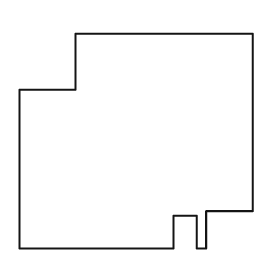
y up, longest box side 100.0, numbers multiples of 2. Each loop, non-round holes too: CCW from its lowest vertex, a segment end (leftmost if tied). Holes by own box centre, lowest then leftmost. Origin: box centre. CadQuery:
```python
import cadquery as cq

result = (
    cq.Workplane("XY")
    .moveTo(-50.0, -46.0)
    .lineTo(16.0, -46.0)
    .lineTo(16.0, -32.0)
    .lineTo(26.0, -32.0)
    .lineTo(26.0, -46.0)
    .lineTo(30.0, -46.0)
    .lineTo(30.0, -30.0)
    .lineTo(50.0, -30.0)
    .lineTo(50.0, 46.0)
    .lineTo(-26.0, 46.0)
    .lineTo(-26.0, 22.0)
    .lineTo(-50.0, 22.0)
    .close()
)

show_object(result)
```